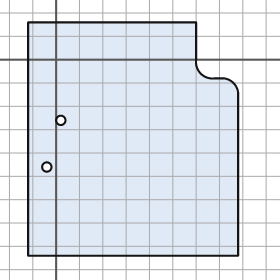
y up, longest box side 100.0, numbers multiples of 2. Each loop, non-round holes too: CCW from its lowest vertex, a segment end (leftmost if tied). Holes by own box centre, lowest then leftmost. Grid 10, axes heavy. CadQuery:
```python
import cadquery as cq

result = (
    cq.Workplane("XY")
    .moveTo(-12.0, -84.0)
    .lineTo(78.0, -84.0)
    .lineTo(78.0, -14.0)
    .threePointArc((76.0, -10.0), (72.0, -8.0))
    .lineTo(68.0, -8.0)
    .threePointArc((62.0, -6.0), (60.0, 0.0))
    .lineTo(60.0, 16.0)
    .lineTo(-12.0, 16.0)
    .close()
    .moveTo(-4.0, -46.0)
    .circle(2.0)
    .moveTo(2.0, -26.0)
    .circle(2.0)
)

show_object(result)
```